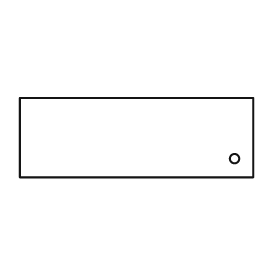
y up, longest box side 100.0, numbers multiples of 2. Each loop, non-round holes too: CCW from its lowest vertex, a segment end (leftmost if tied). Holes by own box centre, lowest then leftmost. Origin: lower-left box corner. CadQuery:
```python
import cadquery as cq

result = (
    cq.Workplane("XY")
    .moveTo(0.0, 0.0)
    .lineTo(100.0, 0.0)
    .lineTo(100.0, 34.0)
    .lineTo(0.0, 34.0)
    .close()
    .moveTo(92.0, 8.0)
    .circle(2.0)
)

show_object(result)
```